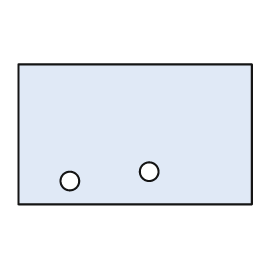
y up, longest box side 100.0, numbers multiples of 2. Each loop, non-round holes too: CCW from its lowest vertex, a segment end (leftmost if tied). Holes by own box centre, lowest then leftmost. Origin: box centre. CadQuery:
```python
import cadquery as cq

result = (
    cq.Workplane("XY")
    .moveTo(-50.0, -30.0)
    .lineTo(50.0, -30.0)
    .lineTo(50.0, 30.0)
    .lineTo(-50.0, 30.0)
    .close()
    .moveTo(-28.0, -20.0)
    .circle(4.0)
    .moveTo(6.0, -16.0)
    .circle(4.0)
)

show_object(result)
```